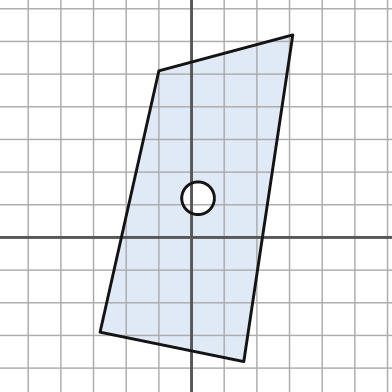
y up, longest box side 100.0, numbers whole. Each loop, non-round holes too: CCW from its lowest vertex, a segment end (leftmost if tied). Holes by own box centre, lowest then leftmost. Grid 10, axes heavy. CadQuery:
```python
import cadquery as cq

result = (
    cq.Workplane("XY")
    .moveTo(16.0, -38.0)
    .lineTo(31.0, 62.0)
    .lineTo(-10.0, 51.0)
    .lineTo(-28.0, -29.0)
    .close()
    .moveTo(2.0, 12.0)
    .circle(5.0)
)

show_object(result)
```